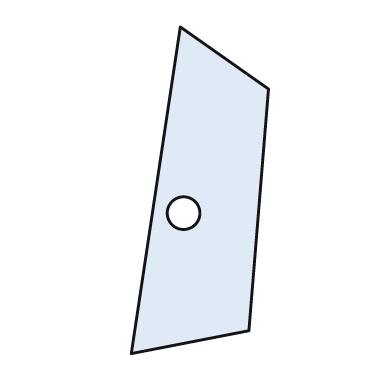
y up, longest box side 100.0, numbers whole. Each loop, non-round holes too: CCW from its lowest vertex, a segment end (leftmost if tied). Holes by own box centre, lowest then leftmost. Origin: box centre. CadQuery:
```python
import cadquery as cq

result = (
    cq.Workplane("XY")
    .moveTo(-21.0, -50.0)
    .lineTo(15.0, -43.0)
    .lineTo(21.0, 31.0)
    .lineTo(-6.0, 50.0)
    .close()
    .moveTo(-5.0, -7.0)
    .circle(5.0)
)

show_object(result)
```